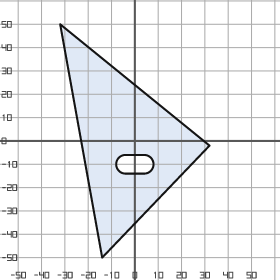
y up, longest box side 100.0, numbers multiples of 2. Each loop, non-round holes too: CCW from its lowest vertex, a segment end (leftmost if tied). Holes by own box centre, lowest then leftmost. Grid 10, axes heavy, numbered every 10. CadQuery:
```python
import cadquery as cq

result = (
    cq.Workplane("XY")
    .moveTo(-14.0, -50.0)
    .lineTo(32.0, -2.0)
    .lineTo(-32.0, 50.0)
    .close()
    .moveTo(-4.0, -14.0)
    .lineTo(4.0, -14.0)
    .threePointArc((8.0, -10.0), (4.0, -6.0))
    .lineTo(-4.0, -6.0)
    .threePointArc((-8.0, -10.0), (-4.0, -14.0))
    .close()
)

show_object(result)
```